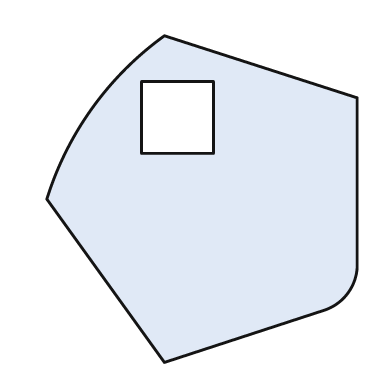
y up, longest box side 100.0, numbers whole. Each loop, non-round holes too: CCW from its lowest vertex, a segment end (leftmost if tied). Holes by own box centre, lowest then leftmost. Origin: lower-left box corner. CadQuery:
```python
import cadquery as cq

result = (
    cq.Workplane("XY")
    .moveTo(36.0, 0.0)
    .lineTo(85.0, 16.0)
    .threePointArc((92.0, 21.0), (95.0, 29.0))
    .lineTo(95.0, 81.0)
    .lineTo(36.0, 100.0)
    .threePointArc((14.0, 78.0), (0.0, 50.0))
    .close()
    .moveTo(29.0, 64.0)
    .lineTo(51.0, 64.0)
    .lineTo(51.0, 86.0)
    .lineTo(29.0, 86.0)
    .close()
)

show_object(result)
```